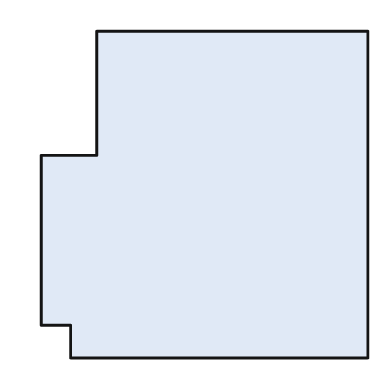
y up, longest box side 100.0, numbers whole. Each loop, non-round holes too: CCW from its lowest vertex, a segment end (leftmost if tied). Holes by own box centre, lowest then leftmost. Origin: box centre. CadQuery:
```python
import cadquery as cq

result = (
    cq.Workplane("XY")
    .moveTo(-41.0, -50.0)
    .lineTo(50.0, -50.0)
    .lineTo(50.0, 50.0)
    .lineTo(-33.0, 50.0)
    .lineTo(-33.0, 12.0)
    .lineTo(-50.0, 12.0)
    .lineTo(-50.0, -40.0)
    .lineTo(-41.0, -40.0)
    .close()
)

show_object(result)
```